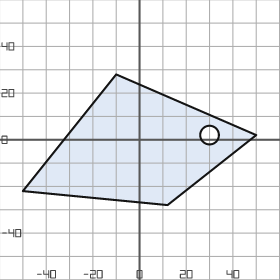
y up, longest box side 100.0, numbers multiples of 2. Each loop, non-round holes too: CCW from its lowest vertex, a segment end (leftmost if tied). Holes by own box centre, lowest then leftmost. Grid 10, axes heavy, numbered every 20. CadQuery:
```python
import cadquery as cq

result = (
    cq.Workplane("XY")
    .moveTo(12.0, -28.0)
    .lineTo(50.0, 2.0)
    .lineTo(-10.0, 28.0)
    .lineTo(-50.0, -22.0)
    .close()
    .moveTo(30.0, 2.0)
    .circle(4.0)
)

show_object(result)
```